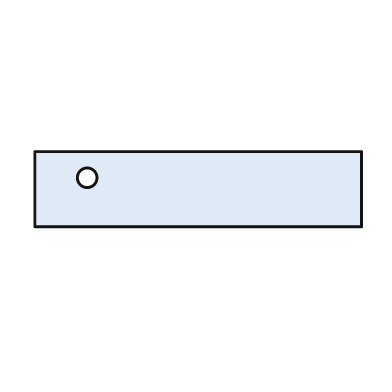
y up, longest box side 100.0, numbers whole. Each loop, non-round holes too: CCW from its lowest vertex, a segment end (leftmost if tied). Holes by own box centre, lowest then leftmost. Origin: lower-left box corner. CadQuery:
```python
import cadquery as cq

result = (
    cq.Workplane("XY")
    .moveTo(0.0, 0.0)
    .lineTo(100.0, 0.0)
    .lineTo(100.0, 23.0)
    .lineTo(0.0, 23.0)
    .close()
    .moveTo(16.0, 15.0)
    .circle(3.0)
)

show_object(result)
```